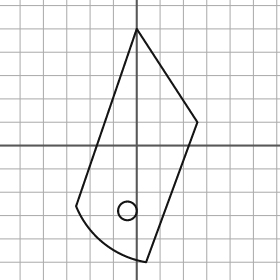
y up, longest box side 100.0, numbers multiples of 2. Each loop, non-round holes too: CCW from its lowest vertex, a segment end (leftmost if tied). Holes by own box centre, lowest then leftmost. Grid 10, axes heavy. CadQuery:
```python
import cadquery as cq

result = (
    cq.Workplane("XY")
    .moveTo(4.0, -50.0)
    .lineTo(26.0, 10.0)
    .lineTo(0.0, 50.0)
    .lineTo(-26.0, -26.0)
    .threePointArc((-14.0, -42.0), (4.0, -50.0))
    .close()
    .moveTo(-4.0, -28.0)
    .circle(4.0)
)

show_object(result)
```